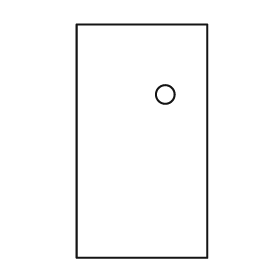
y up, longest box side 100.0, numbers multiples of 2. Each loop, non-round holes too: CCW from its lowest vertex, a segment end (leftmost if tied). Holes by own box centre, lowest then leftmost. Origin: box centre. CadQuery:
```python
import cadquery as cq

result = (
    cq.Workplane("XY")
    .moveTo(-28.0, -50.0)
    .lineTo(28.0, -50.0)
    .lineTo(28.0, 50.0)
    .lineTo(-28.0, 50.0)
    .close()
    .moveTo(10.0, 20.0)
    .circle(4.0)
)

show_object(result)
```